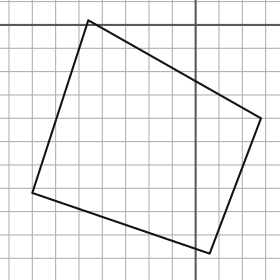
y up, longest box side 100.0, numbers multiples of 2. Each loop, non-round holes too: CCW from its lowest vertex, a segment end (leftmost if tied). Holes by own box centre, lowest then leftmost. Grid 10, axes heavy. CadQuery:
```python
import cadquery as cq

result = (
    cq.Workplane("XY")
    .moveTo(6.0, -98.0)
    .lineTo(28.0, -40.0)
    .lineTo(-46.0, 2.0)
    .lineTo(-70.0, -72.0)
    .close()
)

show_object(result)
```